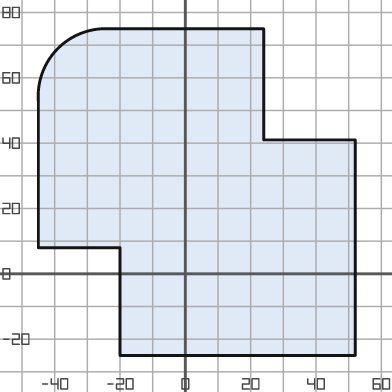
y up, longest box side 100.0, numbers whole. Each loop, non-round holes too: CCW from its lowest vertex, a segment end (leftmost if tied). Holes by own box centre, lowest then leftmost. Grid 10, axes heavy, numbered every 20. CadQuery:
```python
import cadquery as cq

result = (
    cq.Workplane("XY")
    .moveTo(-20.0, -25.0)
    .lineTo(52.0, -25.0)
    .lineTo(52.0, 41.0)
    .lineTo(24.0, 41.0)
    .lineTo(24.0, 75.0)
    .lineTo(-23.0, 75.0)
    .threePointArc((-39.0, 69.0), (-45.0, 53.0))
    .lineTo(-45.0, 8.0)
    .lineTo(-20.0, 8.0)
    .close()
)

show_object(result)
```